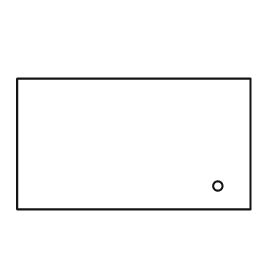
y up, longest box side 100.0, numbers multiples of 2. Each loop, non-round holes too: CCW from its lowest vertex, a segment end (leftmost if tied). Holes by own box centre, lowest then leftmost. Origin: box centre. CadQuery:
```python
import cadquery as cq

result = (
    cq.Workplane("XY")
    .moveTo(-50.0, -28.0)
    .lineTo(50.0, -28.0)
    .lineTo(50.0, 28.0)
    .lineTo(-50.0, 28.0)
    .close()
    .moveTo(36.0, -18.0)
    .circle(2.0)
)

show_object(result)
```